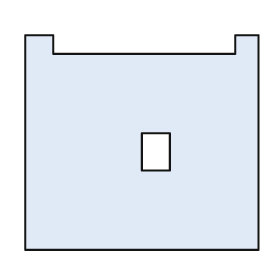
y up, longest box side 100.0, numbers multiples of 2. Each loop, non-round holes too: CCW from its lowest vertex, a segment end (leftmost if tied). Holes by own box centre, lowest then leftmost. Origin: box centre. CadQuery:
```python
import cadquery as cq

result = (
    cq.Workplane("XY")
    .moveTo(-50.0, -46.0)
    .lineTo(50.0, -46.0)
    .lineTo(50.0, 46.0)
    .lineTo(40.0, 46.0)
    .lineTo(40.0, 38.0)
    .lineTo(-38.0, 38.0)
    .lineTo(-38.0, 46.0)
    .lineTo(-50.0, 46.0)
    .close()
    .moveTo(0.0, -12.0)
    .lineTo(12.0, -12.0)
    .lineTo(12.0, 4.0)
    .lineTo(0.0, 4.0)
    .close()
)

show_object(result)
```